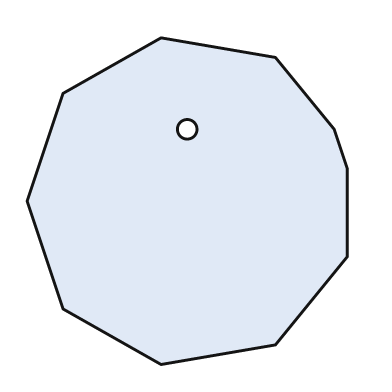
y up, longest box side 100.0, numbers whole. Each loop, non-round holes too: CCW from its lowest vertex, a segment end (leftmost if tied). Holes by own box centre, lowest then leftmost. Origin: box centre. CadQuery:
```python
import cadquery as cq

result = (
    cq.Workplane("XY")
    .moveTo(-8.0, -50.0)
    .lineTo(27.0, -44.0)
    .lineTo(49.0, -17.0)
    .lineTo(49.0, 10.0)
    .lineTo(45.0, 22.0)
    .lineTo(27.0, 44.0)
    .lineTo(-8.0, 50.0)
    .lineTo(-38.0, 33.0)
    .lineTo(-49.0, 0.0)
    .lineTo(-38.0, -33.0)
    .close()
    .moveTo(0.0, 22.0)
    .circle(3.0)
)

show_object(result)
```